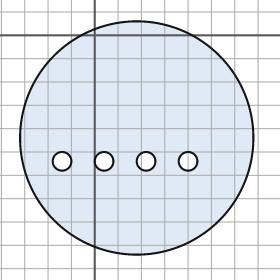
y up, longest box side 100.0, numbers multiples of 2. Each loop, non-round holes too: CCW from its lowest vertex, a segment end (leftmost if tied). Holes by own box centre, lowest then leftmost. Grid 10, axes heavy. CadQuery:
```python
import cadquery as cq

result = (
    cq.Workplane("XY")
    .moveTo(18.0, -44.0)
    .circle(50.0)
    .moveTo(-14.0, -54.0)
    .circle(4.0)
    .moveTo(4.0, -54.0)
    .circle(4.0)
    .moveTo(22.0, -54.0)
    .circle(4.0)
    .moveTo(40.0, -54.0)
    .circle(4.0)
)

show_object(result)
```